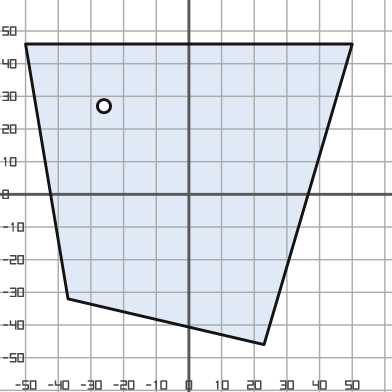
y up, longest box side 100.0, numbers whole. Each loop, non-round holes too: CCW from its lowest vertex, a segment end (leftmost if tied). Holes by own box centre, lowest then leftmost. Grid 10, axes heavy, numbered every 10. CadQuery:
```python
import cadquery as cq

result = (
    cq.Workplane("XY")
    .moveTo(23.0, -46.0)
    .lineTo(50.0, 46.0)
    .lineTo(-50.0, 46.0)
    .lineTo(-37.0, -32.0)
    .close()
    .moveTo(-26.0, 27.0)
    .circle(2.0)
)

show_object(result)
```